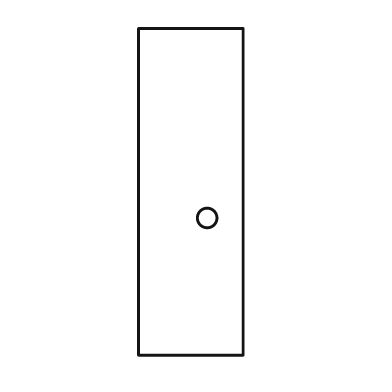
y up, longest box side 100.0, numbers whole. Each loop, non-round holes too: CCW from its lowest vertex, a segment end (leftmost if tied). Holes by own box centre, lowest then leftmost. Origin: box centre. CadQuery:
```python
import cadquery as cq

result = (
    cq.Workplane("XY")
    .moveTo(-16.0, -50.0)
    .lineTo(16.0, -50.0)
    .lineTo(16.0, 50.0)
    .lineTo(-16.0, 50.0)
    .close()
    .moveTo(5.0, -8.0)
    .circle(3.0)
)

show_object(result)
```